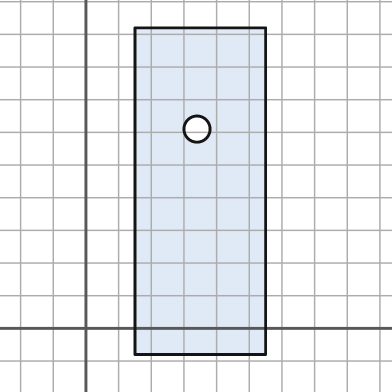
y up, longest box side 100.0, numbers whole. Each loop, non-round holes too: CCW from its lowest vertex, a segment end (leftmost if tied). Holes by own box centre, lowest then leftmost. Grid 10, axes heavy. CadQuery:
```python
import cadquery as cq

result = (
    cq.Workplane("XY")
    .moveTo(15.0, -8.0)
    .lineTo(55.0, -8.0)
    .lineTo(55.0, 92.0)
    .lineTo(15.0, 92.0)
    .close()
    .moveTo(34.0, 61.0)
    .circle(4.0)
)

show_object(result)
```